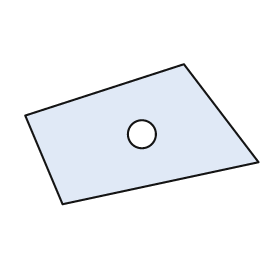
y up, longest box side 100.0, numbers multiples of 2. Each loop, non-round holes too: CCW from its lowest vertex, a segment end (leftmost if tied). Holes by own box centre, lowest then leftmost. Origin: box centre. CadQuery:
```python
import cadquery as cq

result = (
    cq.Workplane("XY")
    .moveTo(-34.0, -30.0)
    .lineTo(50.0, -12.0)
    .lineTo(18.0, 30.0)
    .lineTo(-50.0, 8.0)
    .close()
    .moveTo(0.0, 0.0)
    .circle(6.0)
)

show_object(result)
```